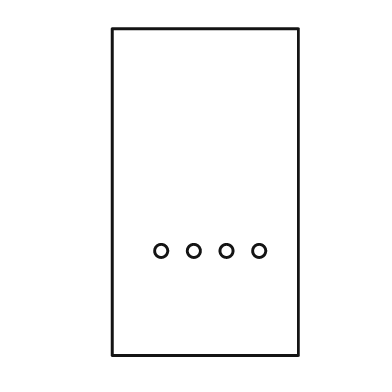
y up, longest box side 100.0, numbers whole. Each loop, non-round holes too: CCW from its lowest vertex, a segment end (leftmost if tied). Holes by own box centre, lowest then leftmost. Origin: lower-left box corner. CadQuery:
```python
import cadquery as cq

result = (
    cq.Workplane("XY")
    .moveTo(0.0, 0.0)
    .lineTo(57.0, 0.0)
    .lineTo(57.0, 100.0)
    .lineTo(0.0, 100.0)
    .close()
    .moveTo(15.0, 32.0)
    .circle(2.0)
    .moveTo(25.0, 32.0)
    .circle(2.0)
    .moveTo(35.0, 32.0)
    .circle(2.0)
    .moveTo(45.0, 32.0)
    .circle(2.0)
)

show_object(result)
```